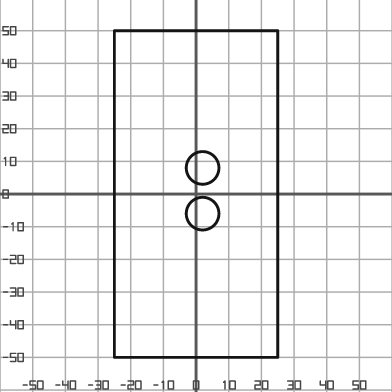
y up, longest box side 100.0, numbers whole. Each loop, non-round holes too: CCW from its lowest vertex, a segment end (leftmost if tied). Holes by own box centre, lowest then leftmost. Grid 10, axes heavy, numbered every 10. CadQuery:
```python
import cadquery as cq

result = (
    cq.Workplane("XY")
    .moveTo(-25.0, -50.0)
    .lineTo(25.0, -50.0)
    .lineTo(25.0, 50.0)
    .lineTo(-25.0, 50.0)
    .close()
    .moveTo(2.0, -6.0)
    .circle(5.0)
    .moveTo(2.0, 8.0)
    .circle(5.0)
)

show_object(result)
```